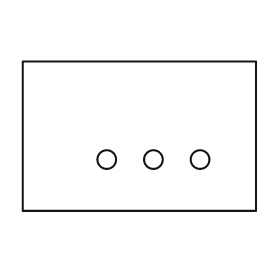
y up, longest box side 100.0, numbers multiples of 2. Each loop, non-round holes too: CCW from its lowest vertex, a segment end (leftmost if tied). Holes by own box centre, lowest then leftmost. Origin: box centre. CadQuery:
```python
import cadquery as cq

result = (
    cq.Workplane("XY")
    .moveTo(-50.0, -32.0)
    .lineTo(50.0, -32.0)
    .lineTo(50.0, 32.0)
    .lineTo(-50.0, 32.0)
    .close()
    .moveTo(-14.0, -10.0)
    .circle(4.0)
    .moveTo(6.0, -10.0)
    .circle(4.0)
    .moveTo(26.0, -10.0)
    .circle(4.0)
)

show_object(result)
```